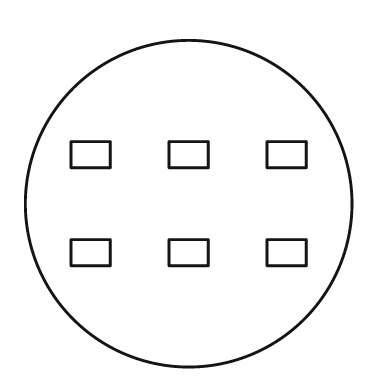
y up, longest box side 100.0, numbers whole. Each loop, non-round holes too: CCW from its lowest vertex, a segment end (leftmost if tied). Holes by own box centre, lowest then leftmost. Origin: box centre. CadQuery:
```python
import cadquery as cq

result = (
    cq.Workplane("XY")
    .moveTo(0.0, 0.0)
    .circle(50.0)
    .moveTo(-36.0, -19.0)
    .lineTo(-24.0, -19.0)
    .lineTo(-24.0, -11.0)
    .lineTo(-36.0, -11.0)
    .close()
    .moveTo(-6.0, -19.0)
    .lineTo(6.0, -19.0)
    .lineTo(6.0, -11.0)
    .lineTo(-6.0, -11.0)
    .close()
    .moveTo(24.0, -19.0)
    .lineTo(36.0, -19.0)
    .lineTo(36.0, -11.0)
    .lineTo(24.0, -11.0)
    .close()
    .moveTo(-36.0, 11.0)
    .lineTo(-24.0, 11.0)
    .lineTo(-24.0, 19.0)
    .lineTo(-36.0, 19.0)
    .close()
    .moveTo(-6.0, 11.0)
    .lineTo(6.0, 11.0)
    .lineTo(6.0, 19.0)
    .lineTo(-6.0, 19.0)
    .close()
    .moveTo(24.0, 11.0)
    .lineTo(36.0, 11.0)
    .lineTo(36.0, 19.0)
    .lineTo(24.0, 19.0)
    .close()
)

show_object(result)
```